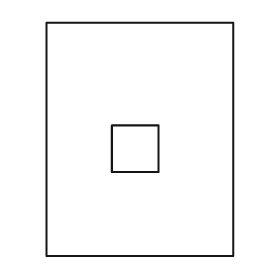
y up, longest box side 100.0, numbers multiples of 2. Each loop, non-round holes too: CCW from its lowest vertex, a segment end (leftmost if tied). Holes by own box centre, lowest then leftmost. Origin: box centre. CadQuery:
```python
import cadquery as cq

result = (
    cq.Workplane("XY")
    .moveTo(-40.0, -50.0)
    .lineTo(40.0, -50.0)
    .lineTo(40.0, 50.0)
    .lineTo(-40.0, 50.0)
    .close()
    .moveTo(-12.0, -14.0)
    .lineTo(8.0, -14.0)
    .lineTo(8.0, 6.0)
    .lineTo(-12.0, 6.0)
    .close()
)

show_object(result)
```